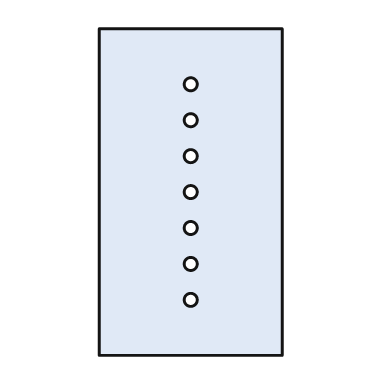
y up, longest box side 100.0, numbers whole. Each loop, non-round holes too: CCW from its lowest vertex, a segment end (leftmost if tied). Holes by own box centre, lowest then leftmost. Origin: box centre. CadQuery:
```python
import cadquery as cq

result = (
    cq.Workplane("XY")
    .moveTo(-28.0, -50.0)
    .lineTo(28.0, -50.0)
    .lineTo(28.0, 50.0)
    .lineTo(-28.0, 50.0)
    .close()
    .moveTo(0.0, -33.0)
    .circle(2.0)
    .moveTo(0.0, -22.0)
    .circle(2.0)
    .moveTo(0.0, -11.0)
    .circle(2.0)
    .moveTo(0.0, 0.0)
    .circle(2.0)
    .moveTo(0.0, 11.0)
    .circle(2.0)
    .moveTo(0.0, 22.0)
    .circle(2.0)
    .moveTo(0.0, 33.0)
    .circle(2.0)
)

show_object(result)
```